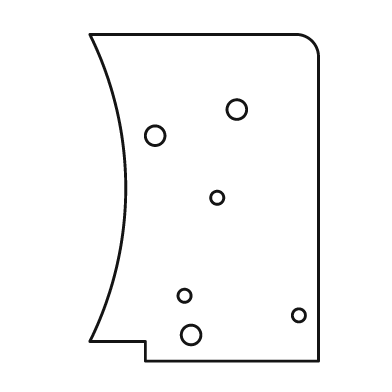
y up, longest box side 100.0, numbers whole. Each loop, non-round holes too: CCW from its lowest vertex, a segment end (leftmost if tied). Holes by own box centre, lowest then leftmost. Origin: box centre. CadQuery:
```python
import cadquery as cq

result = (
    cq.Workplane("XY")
    .moveTo(-18.0, -50.0)
    .lineTo(35.0, -50.0)
    .lineTo(35.0, 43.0)
    .threePointArc((33.0, 48.0), (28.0, 50.0))
    .lineTo(-35.0, 50.0)
    .threePointArc((-24.0, 3.0), (-35.0, -44.0))
    .lineTo(-18.0, -44.0)
    .close()
    .moveTo(-4.0, -42.0)
    .circle(3.0)
    .moveTo(29.0, -36.0)
    .circle(2.0)
    .moveTo(-6.0, -30.0)
    .circle(2.0)
    .moveTo(4.0, 0.0)
    .circle(2.0)
    .moveTo(-15.0, 19.0)
    .circle(3.0)
    .moveTo(10.0, 27.0)
    .circle(3.0)
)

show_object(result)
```